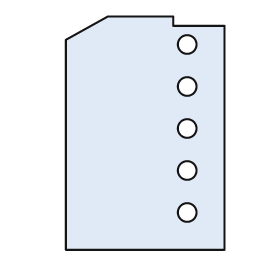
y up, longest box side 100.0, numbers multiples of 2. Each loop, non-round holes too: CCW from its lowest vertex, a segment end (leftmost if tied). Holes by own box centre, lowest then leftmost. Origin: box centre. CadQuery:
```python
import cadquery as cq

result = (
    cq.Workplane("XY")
    .moveTo(-34.0, -50.0)
    .lineTo(34.0, -50.0)
    .lineTo(34.0, 46.0)
    .lineTo(12.0, 46.0)
    .lineTo(12.0, 50.0)
    .lineTo(-16.0, 50.0)
    .lineTo(-34.0, 40.0)
    .close()
    .moveTo(18.0, -34.0)
    .circle(4.0)
    .moveTo(18.0, -16.0)
    .circle(4.0)
    .moveTo(18.0, 2.0)
    .circle(4.0)
    .moveTo(18.0, 20.0)
    .circle(4.0)
    .moveTo(18.0, 38.0)
    .circle(4.0)
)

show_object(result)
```